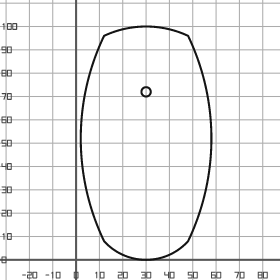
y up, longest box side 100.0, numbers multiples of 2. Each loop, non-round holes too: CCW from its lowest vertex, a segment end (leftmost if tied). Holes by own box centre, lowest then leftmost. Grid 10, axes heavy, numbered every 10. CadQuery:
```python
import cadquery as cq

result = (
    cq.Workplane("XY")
    .moveTo(12.0, 8.0)
    .threePointArc((30.0, 0.0), (48.0, 8.0))
    .threePointArc((58.0, 52.0), (48.0, 96.0))
    .threePointArc((30.0, 100.0), (12.0, 96.0))
    .threePointArc((2.0, 52.0), (12.0, 8.0))
    .close()
    .moveTo(30.0, 72.0)
    .circle(2.0)
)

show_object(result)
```